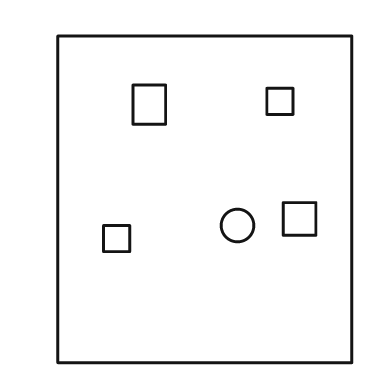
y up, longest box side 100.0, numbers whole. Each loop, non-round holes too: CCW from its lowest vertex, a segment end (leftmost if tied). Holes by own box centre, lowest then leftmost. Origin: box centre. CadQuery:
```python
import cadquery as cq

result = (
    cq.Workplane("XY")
    .moveTo(-45.0, -50.0)
    .lineTo(45.0, -50.0)
    .lineTo(45.0, 50.0)
    .lineTo(-45.0, 50.0)
    .close()
    .moveTo(-31.0, -16.0)
    .lineTo(-23.0, -16.0)
    .lineTo(-23.0, -8.0)
    .lineTo(-31.0, -8.0)
    .close()
    .moveTo(10.0, -8.0)
    .circle(5.0)
    .moveTo(24.0, -11.0)
    .lineTo(34.0, -11.0)
    .lineTo(34.0, -1.0)
    .lineTo(24.0, -1.0)
    .close()
    .moveTo(-22.0, 23.0)
    .lineTo(-12.0, 23.0)
    .lineTo(-12.0, 35.0)
    .lineTo(-22.0, 35.0)
    .close()
    .moveTo(19.0, 26.0)
    .lineTo(27.0, 26.0)
    .lineTo(27.0, 34.0)
    .lineTo(19.0, 34.0)
    .close()
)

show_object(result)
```